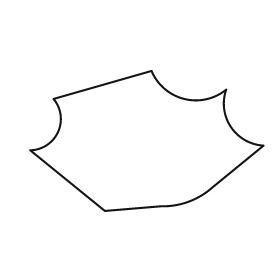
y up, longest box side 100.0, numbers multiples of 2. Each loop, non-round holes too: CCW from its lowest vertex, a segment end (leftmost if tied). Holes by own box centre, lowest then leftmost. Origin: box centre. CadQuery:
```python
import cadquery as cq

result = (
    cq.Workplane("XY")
    .moveTo(-18.0, -30.0)
    .lineTo(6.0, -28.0)
    .threePointArc((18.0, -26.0), (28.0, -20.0))
    .lineTo(50.0, -2.0)
    .threePointArc((36.0, 6.0), (34.0, 22.0))
    .threePointArc((16.0, 18.0), (2.0, 30.0))
    .lineTo(-40.0, 18.0)
    .threePointArc((-38.0, 4.0), (-50.0, -4.0))
    .close()
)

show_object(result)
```